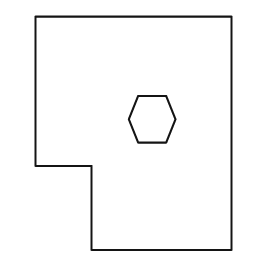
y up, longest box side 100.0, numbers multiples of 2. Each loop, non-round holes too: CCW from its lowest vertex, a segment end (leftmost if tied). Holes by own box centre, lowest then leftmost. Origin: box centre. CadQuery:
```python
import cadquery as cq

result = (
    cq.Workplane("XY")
    .moveTo(-18.0, -50.0)
    .lineTo(42.0, -50.0)
    .lineTo(42.0, 50.0)
    .lineTo(-42.0, 50.0)
    .lineTo(-42.0, -14.0)
    .lineTo(-18.0, -14.0)
    .close()
    .moveTo(2.0, -4.0)
    .lineTo(14.0, -4.0)
    .lineTo(18.0, 6.0)
    .lineTo(14.0, 16.0)
    .lineTo(2.0, 16.0)
    .lineTo(-2.0, 6.0)
    .close()
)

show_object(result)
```